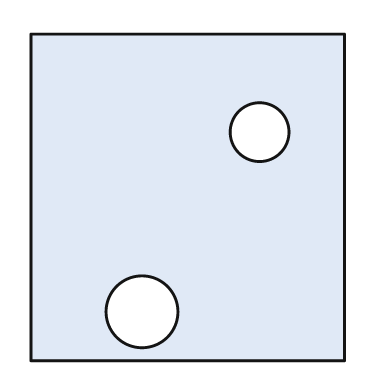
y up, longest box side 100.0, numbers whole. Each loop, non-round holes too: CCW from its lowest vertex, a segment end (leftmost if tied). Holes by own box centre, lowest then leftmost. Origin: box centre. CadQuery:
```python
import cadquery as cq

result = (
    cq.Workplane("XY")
    .moveTo(-48.0, -50.0)
    .lineTo(48.0, -50.0)
    .lineTo(48.0, 50.0)
    .lineTo(-48.0, 50.0)
    .close()
    .moveTo(-14.0, -35.0)
    .circle(11.0)
    .moveTo(22.0, 20.0)
    .circle(9.0)
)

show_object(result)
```